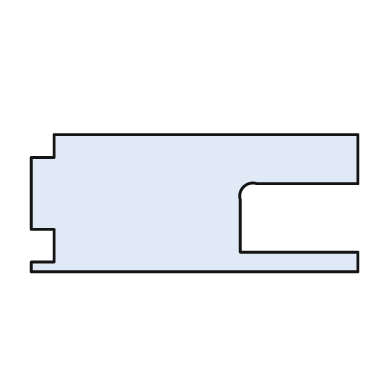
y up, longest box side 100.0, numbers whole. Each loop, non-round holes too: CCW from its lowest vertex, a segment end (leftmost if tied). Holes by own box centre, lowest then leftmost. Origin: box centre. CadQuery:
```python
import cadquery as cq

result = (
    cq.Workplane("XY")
    .moveTo(-50.0, -21.0)
    .lineTo(50.0, -21.0)
    .lineTo(50.0, -15.0)
    .lineTo(14.0, -15.0)
    .lineTo(14.0, 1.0)
    .threePointArc((15.0, 5.0), (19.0, 6.0))
    .lineTo(50.0, 6.0)
    .lineTo(50.0, 21.0)
    .lineTo(-43.0, 21.0)
    .lineTo(-43.0, 14.0)
    .lineTo(-50.0, 14.0)
    .lineTo(-50.0, -8.0)
    .lineTo(-43.0, -8.0)
    .lineTo(-43.0, -18.0)
    .lineTo(-50.0, -18.0)
    .close()
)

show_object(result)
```